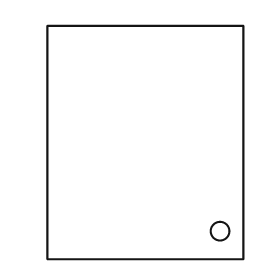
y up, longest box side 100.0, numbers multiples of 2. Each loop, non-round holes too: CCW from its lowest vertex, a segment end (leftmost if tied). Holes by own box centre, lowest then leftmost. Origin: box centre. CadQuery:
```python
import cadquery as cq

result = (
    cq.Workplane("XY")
    .moveTo(-42.0, -50.0)
    .lineTo(42.0, -50.0)
    .lineTo(42.0, 50.0)
    .lineTo(-42.0, 50.0)
    .close()
    .moveTo(32.0, -38.0)
    .circle(4.0)
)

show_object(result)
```